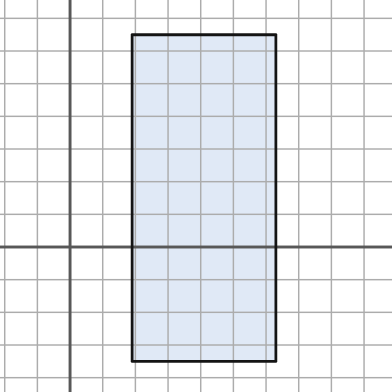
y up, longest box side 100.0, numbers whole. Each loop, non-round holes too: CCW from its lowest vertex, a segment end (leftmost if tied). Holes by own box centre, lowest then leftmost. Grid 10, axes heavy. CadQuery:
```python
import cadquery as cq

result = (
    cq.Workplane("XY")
    .moveTo(19.0, -35.0)
    .lineTo(63.0, -35.0)
    .lineTo(63.0, 65.0)
    .lineTo(19.0, 65.0)
    .close()
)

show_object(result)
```